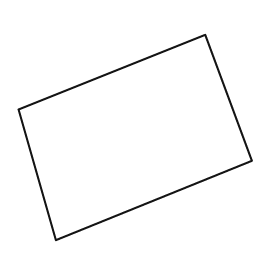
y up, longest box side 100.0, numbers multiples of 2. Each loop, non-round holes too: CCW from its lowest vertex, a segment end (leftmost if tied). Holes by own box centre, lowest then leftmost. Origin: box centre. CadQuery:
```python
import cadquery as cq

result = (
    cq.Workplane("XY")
    .moveTo(-34.0, -44.0)
    .lineTo(50.0, -10.0)
    .lineTo(30.0, 44.0)
    .lineTo(-50.0, 12.0)
    .close()
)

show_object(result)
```